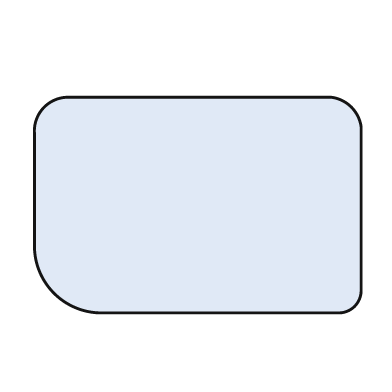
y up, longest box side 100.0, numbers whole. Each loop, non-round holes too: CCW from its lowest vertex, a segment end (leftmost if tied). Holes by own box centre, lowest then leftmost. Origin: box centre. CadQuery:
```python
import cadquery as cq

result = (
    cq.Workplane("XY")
    .moveTo(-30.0, -33.0)
    .lineTo(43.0, -33.0)
    .threePointArc((48.0, -31.0), (50.0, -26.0))
    .lineTo(50.0, 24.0)
    .threePointArc((47.0, 30.0), (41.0, 33.0))
    .lineTo(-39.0, 33.0)
    .threePointArc((-47.0, 30.0), (-50.0, 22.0))
    .lineTo(-50.0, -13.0)
    .threePointArc((-44.0, -27.0), (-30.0, -33.0))
    .close()
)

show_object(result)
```